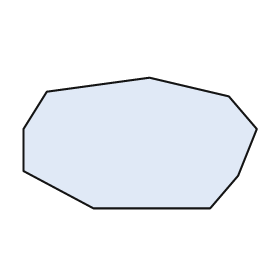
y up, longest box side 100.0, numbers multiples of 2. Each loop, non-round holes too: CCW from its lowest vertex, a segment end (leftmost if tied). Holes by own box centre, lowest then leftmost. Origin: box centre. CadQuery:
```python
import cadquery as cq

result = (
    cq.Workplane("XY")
    .moveTo(-20.0, -28.0)
    .lineTo(30.0, -28.0)
    .lineTo(42.0, -14.0)
    .lineTo(50.0, 6.0)
    .lineTo(38.0, 20.0)
    .lineTo(4.0, 28.0)
    .lineTo(-40.0, 22.0)
    .lineTo(-50.0, 6.0)
    .lineTo(-50.0, -12.0)
    .close()
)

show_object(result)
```